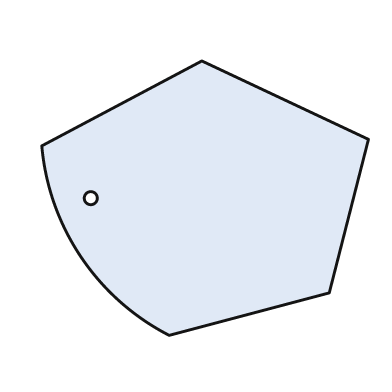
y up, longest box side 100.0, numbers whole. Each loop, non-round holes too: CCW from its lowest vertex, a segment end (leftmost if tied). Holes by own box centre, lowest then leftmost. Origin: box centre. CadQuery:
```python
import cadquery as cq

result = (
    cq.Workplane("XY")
    .moveTo(-11.0, -42.0)
    .lineTo(38.0, -29.0)
    .lineTo(50.0, 18.0)
    .lineTo(-1.0, 42.0)
    .lineTo(-50.0, 16.0)
    .threePointArc((-38.0, -18.0), (-11.0, -42.0))
    .close()
    .moveTo(-35.0, 0.0)
    .circle(2.0)
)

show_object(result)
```